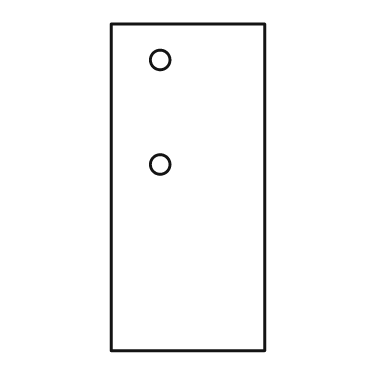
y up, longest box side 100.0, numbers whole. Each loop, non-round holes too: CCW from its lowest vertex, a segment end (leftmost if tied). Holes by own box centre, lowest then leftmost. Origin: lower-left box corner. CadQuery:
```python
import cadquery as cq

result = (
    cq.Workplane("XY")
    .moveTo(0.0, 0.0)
    .lineTo(47.0, 0.0)
    .lineTo(47.0, 100.0)
    .lineTo(0.0, 100.0)
    .close()
    .moveTo(15.0, 57.0)
    .circle(3.0)
    .moveTo(15.0, 89.0)
    .circle(3.0)
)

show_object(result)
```